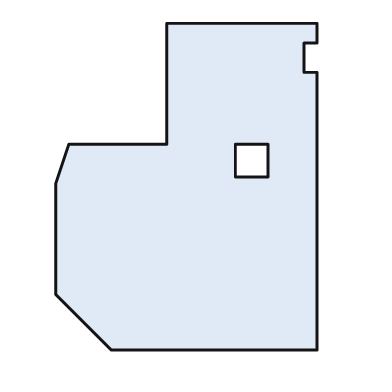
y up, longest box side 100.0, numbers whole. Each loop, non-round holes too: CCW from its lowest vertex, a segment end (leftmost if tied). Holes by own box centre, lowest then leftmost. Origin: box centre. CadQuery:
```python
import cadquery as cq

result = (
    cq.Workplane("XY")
    .moveTo(-23.0, -50.0)
    .lineTo(40.0, -50.0)
    .lineTo(40.0, 35.0)
    .lineTo(36.0, 35.0)
    .lineTo(36.0, 44.0)
    .lineTo(40.0, 44.0)
    .lineTo(40.0, 50.0)
    .lineTo(-6.0, 50.0)
    .lineTo(-6.0, 13.0)
    .lineTo(-36.0, 13.0)
    .lineTo(-40.0, 1.0)
    .lineTo(-40.0, -33.0)
    .close()
    .moveTo(15.0, 3.0)
    .lineTo(25.0, 3.0)
    .lineTo(25.0, 13.0)
    .lineTo(15.0, 13.0)
    .close()
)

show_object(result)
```